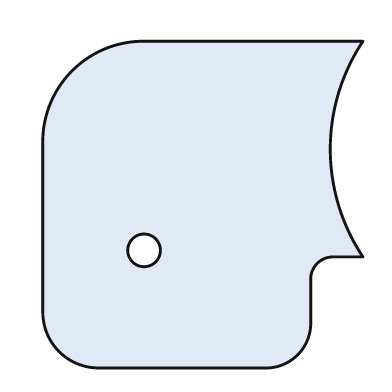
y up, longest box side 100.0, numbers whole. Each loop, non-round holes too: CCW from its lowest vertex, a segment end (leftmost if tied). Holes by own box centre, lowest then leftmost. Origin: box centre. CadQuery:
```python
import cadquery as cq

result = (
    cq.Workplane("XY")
    .moveTo(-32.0, -50.0)
    .lineTo(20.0, -50.0)
    .threePointArc((29.0, -46.0), (33.0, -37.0))
    .lineTo(33.0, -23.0)
    .threePointArc((35.0, -18.0), (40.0, -16.0))
    .lineTo(49.0, -16.0)
    .threePointArc((39.0, 17.0), (49.0, 50.0))
    .lineTo(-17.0, 50.0)
    .threePointArc((-40.0, 41.0), (-49.0, 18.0))
    .lineTo(-49.0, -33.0)
    .threePointArc((-44.0, -45.0), (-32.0, -50.0))
    .close()
    .moveTo(-18.0, -14.0)
    .circle(5.0)
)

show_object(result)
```